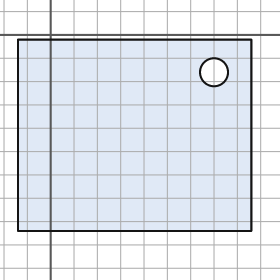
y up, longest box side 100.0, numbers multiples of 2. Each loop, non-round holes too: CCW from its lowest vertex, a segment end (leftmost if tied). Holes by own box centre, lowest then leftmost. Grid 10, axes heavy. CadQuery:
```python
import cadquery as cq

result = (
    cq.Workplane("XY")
    .moveTo(-14.0, -84.0)
    .lineTo(86.0, -84.0)
    .lineTo(86.0, -2.0)
    .lineTo(-14.0, -2.0)
    .close()
    .moveTo(70.0, -16.0)
    .circle(6.0)
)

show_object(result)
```